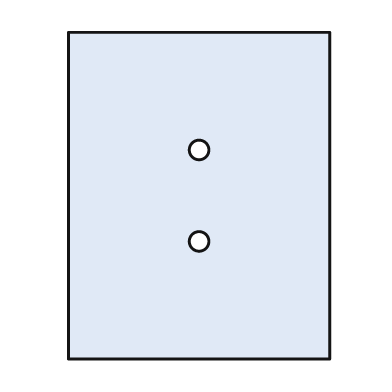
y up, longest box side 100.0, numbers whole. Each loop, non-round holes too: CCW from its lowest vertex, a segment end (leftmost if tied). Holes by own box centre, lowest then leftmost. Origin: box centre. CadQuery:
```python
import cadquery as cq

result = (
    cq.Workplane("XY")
    .moveTo(-40.0, -50.0)
    .lineTo(40.0, -50.0)
    .lineTo(40.0, 50.0)
    .lineTo(-40.0, 50.0)
    .close()
    .moveTo(0.0, -14.0)
    .circle(3.0)
    .moveTo(0.0, 14.0)
    .circle(3.0)
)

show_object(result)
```